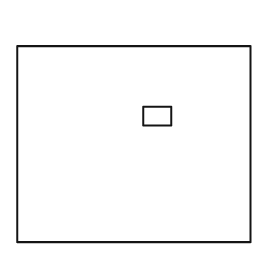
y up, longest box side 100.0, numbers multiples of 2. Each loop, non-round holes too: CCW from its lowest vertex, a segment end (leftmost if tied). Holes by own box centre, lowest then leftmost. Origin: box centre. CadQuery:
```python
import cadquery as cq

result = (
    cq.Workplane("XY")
    .moveTo(-50.0, -42.0)
    .lineTo(50.0, -42.0)
    .lineTo(50.0, 42.0)
    .lineTo(-50.0, 42.0)
    .close()
    .moveTo(4.0, 8.0)
    .lineTo(16.0, 8.0)
    .lineTo(16.0, 16.0)
    .lineTo(4.0, 16.0)
    .close()
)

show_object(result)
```